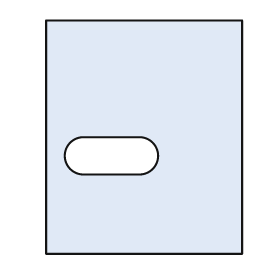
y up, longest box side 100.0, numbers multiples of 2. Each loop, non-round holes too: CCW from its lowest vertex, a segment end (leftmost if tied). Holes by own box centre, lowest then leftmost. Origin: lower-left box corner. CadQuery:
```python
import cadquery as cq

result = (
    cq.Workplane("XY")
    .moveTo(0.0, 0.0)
    .lineTo(84.0, 0.0)
    .lineTo(84.0, 100.0)
    .lineTo(0.0, 100.0)
    .close()
    .moveTo(16.0, 34.0)
    .lineTo(40.0, 34.0)
    .threePointArc((48.0, 42.0), (40.0, 50.0))
    .lineTo(16.0, 50.0)
    .threePointArc((8.0, 42.0), (16.0, 34.0))
    .close()
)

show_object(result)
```